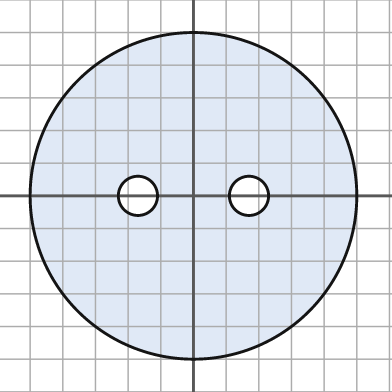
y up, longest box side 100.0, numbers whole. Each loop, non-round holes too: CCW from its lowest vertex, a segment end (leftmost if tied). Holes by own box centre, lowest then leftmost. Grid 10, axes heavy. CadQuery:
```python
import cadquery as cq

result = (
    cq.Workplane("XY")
    .moveTo(0.0, 0.0)
    .circle(50.0)
    .moveTo(-17.0, 0.0)
    .circle(6.0)
    .moveTo(17.0, 0.0)
    .circle(6.0)
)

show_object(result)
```